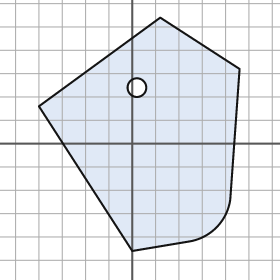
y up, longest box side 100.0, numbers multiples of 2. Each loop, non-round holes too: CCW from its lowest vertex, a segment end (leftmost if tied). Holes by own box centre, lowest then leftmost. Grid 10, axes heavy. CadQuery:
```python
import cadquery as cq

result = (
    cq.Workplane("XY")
    .moveTo(0.0, -46.0)
    .lineTo(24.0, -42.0)
    .threePointArc((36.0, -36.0), (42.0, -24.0))
    .lineTo(46.0, 32.0)
    .lineTo(12.0, 54.0)
    .lineTo(-40.0, 16.0)
    .close()
    .moveTo(2.0, 24.0)
    .circle(4.0)
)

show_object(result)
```